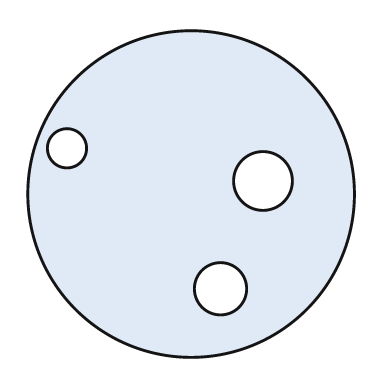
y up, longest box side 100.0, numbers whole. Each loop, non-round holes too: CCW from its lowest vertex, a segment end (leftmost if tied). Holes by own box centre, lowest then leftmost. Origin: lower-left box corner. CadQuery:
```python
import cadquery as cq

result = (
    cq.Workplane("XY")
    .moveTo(50.0, 50.0)
    .circle(50.0)
    .moveTo(59.0, 21.0)
    .circle(8.0)
    .moveTo(72.0, 54.0)
    .circle(9.0)
    .moveTo(12.0, 64.0)
    .circle(6.0)
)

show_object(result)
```